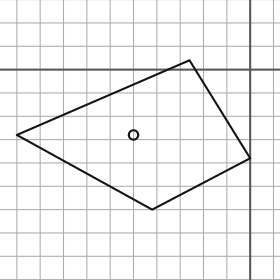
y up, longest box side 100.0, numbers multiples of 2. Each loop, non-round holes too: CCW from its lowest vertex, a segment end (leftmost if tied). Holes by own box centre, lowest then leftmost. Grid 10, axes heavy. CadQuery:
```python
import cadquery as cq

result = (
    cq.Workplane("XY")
    .moveTo(-42.0, -60.0)
    .lineTo(0.0, -38.0)
    .lineTo(-26.0, 4.0)
    .lineTo(-100.0, -28.0)
    .close()
    .moveTo(-50.0, -28.0)
    .circle(2.0)
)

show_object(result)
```